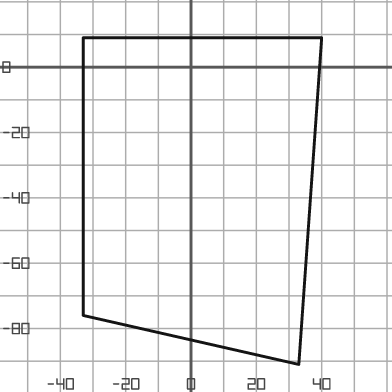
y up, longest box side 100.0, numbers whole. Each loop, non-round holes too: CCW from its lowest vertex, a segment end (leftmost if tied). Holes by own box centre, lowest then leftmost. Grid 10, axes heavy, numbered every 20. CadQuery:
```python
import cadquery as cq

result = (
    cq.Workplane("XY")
    .moveTo(33.0, -91.0)
    .lineTo(40.0, 9.0)
    .lineTo(-33.0, 9.0)
    .lineTo(-33.0, -76.0)
    .close()
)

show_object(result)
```